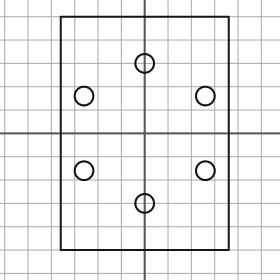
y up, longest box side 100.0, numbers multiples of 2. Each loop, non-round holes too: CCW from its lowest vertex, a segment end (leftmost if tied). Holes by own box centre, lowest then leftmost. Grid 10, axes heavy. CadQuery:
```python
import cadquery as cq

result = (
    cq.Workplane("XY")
    .moveTo(-36.0, -50.0)
    .lineTo(36.0, -50.0)
    .lineTo(36.0, 50.0)
    .lineTo(-36.0, 50.0)
    .close()
    .moveTo(0.0, -30.0)
    .circle(4.0)
    .moveTo(-26.0, -16.0)
    .circle(4.0)
    .moveTo(26.0, -16.0)
    .circle(4.0)
    .moveTo(-26.0, 16.0)
    .circle(4.0)
    .moveTo(26.0, 16.0)
    .circle(4.0)
    .moveTo(0.0, 30.0)
    .circle(4.0)
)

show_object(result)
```